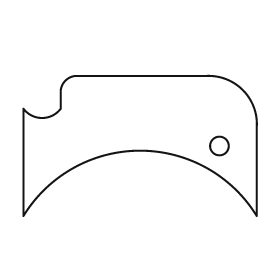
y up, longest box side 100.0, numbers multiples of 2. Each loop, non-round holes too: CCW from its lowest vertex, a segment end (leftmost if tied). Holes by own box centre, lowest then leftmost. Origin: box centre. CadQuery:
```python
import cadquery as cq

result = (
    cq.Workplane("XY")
    .moveTo(-50.0, -30.0)
    .threePointArc((0.0, -2.0), (50.0, -30.0))
    .lineTo(50.0, 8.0)
    .threePointArc((44.0, 24.0), (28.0, 30.0))
    .lineTo(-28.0, 30.0)
    .threePointArc((-32.0, 28.0), (-34.0, 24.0))
    .lineTo(-34.0, 16.0)
    .threePointArc((-42.0, 12.0), (-50.0, 16.0))
    .close()
    .moveTo(34.0, 0.0)
    .circle(4.0)
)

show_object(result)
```